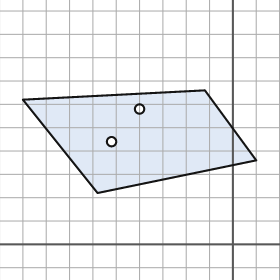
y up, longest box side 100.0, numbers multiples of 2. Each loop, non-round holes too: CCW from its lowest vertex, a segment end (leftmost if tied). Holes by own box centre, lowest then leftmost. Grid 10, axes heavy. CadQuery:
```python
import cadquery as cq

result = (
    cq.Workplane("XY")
    .moveTo(-58.0, 22.0)
    .lineTo(10.0, 36.0)
    .lineTo(-12.0, 66.0)
    .lineTo(-90.0, 62.0)
    .close()
    .moveTo(-52.0, 44.0)
    .circle(2.0)
    .moveTo(-40.0, 58.0)
    .circle(2.0)
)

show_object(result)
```